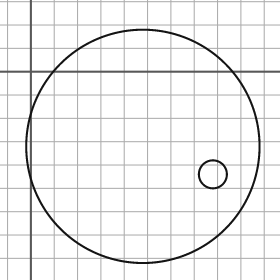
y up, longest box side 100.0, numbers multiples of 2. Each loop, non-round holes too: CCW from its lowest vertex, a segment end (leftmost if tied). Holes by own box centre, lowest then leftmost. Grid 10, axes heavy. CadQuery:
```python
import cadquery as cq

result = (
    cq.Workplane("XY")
    .moveTo(48.0, -32.0)
    .circle(50.0)
    .moveTo(78.0, -44.0)
    .circle(6.0)
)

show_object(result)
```